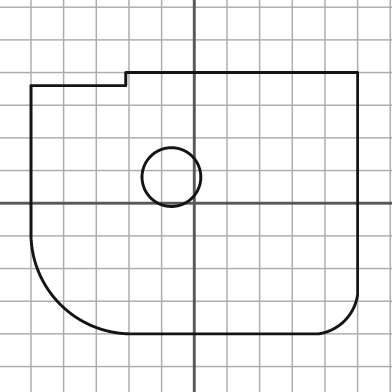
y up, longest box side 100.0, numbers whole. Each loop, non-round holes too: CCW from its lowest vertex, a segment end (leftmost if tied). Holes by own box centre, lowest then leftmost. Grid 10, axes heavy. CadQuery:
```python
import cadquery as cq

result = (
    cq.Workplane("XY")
    .moveTo(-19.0, -40.0)
    .lineTo(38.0, -40.0)
    .threePointArc((46.0, -36.0), (50.0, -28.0))
    .lineTo(50.0, 40.0)
    .lineTo(-21.0, 40.0)
    .lineTo(-21.0, 36.0)
    .lineTo(-50.0, 36.0)
    .lineTo(-50.0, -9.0)
    .threePointArc((-41.0, -31.0), (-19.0, -40.0))
    .close()
    .moveTo(-7.0, 8.0)
    .circle(9.0)
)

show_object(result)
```